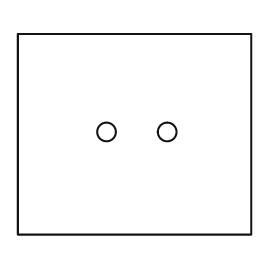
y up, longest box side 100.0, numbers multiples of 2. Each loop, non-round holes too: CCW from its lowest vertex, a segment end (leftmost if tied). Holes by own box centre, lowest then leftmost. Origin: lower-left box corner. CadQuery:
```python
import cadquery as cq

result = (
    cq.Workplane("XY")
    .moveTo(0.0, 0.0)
    .lineTo(100.0, 0.0)
    .lineTo(100.0, 86.0)
    .lineTo(0.0, 86.0)
    .close()
    .moveTo(38.0, 44.0)
    .circle(4.0)
    .moveTo(64.0, 44.0)
    .circle(4.0)
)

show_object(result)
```